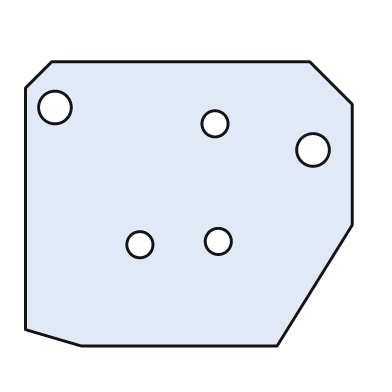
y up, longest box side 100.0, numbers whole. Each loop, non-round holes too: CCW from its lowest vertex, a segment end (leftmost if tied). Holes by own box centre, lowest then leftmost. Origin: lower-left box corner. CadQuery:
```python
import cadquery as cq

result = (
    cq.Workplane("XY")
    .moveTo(17.0, 0.0)
    .lineTo(77.0, 0.0)
    .lineTo(100.0, 37.0)
    .lineTo(100.0, 74.0)
    .lineTo(87.0, 87.0)
    .lineTo(8.0, 87.0)
    .lineTo(0.0, 79.0)
    .lineTo(0.0, 5.0)
    .close()
    .moveTo(35.0, 31.0)
    .circle(4.0)
    .moveTo(59.0, 32.0)
    .circle(4.0)
    .moveTo(88.0, 60.0)
    .circle(5.0)
    .moveTo(58.0, 68.0)
    .circle(4.0)
    .moveTo(9.0, 73.0)
    .circle(5.0)
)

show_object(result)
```